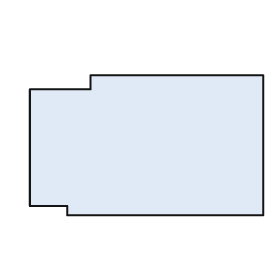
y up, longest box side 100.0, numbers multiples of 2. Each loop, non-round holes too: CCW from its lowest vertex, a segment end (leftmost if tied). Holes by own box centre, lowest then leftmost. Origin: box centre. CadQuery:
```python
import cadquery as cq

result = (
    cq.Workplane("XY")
    .moveTo(-34.0, -30.0)
    .lineTo(50.0, -30.0)
    .lineTo(50.0, 30.0)
    .lineTo(-24.0, 30.0)
    .lineTo(-24.0, 24.0)
    .lineTo(-50.0, 24.0)
    .lineTo(-50.0, -26.0)
    .lineTo(-34.0, -26.0)
    .close()
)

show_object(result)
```